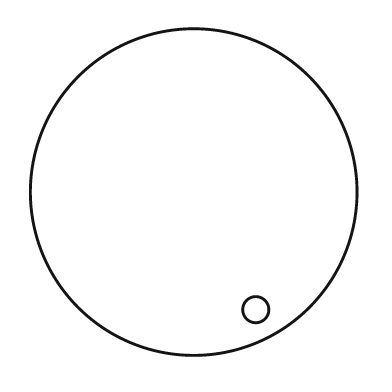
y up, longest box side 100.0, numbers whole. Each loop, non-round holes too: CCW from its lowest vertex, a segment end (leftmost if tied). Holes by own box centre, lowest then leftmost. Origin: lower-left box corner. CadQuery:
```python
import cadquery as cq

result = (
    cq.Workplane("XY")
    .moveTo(50.0, 50.0)
    .circle(50.0)
    .moveTo(69.0, 14.0)
    .circle(4.0)
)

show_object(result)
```